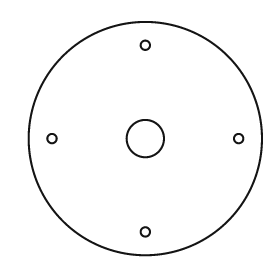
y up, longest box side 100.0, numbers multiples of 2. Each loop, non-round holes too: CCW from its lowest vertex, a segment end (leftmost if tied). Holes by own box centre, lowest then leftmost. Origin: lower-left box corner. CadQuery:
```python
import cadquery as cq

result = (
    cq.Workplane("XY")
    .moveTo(50.0, 50.0)
    .circle(50.0)
    .moveTo(50.0, 10.0)
    .circle(2.0)
    .moveTo(10.0, 50.0)
    .circle(2.0)
    .moveTo(50.0, 50.0)
    .circle(8.0)
    .moveTo(90.0, 50.0)
    .circle(2.0)
    .moveTo(50.0, 90.0)
    .circle(2.0)
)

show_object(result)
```